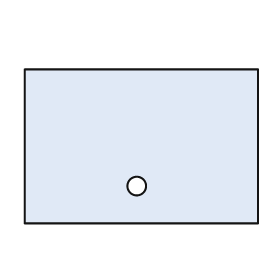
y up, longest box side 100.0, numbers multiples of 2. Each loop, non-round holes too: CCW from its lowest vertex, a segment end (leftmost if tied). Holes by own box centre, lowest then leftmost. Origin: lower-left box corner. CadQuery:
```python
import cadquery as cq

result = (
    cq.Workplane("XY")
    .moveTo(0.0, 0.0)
    .lineTo(100.0, 0.0)
    .lineTo(100.0, 66.0)
    .lineTo(0.0, 66.0)
    .close()
    .moveTo(48.0, 16.0)
    .circle(4.0)
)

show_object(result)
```